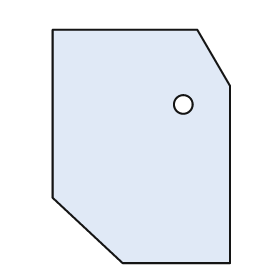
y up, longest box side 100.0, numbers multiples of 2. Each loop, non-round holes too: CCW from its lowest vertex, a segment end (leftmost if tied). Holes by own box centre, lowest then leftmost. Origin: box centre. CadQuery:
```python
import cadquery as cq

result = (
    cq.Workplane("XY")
    .moveTo(-8.0, -50.0)
    .lineTo(38.0, -50.0)
    .lineTo(38.0, 26.0)
    .lineTo(24.0, 50.0)
    .lineTo(-38.0, 50.0)
    .lineTo(-38.0, -22.0)
    .close()
    .moveTo(18.0, 18.0)
    .circle(4.0)
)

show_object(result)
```